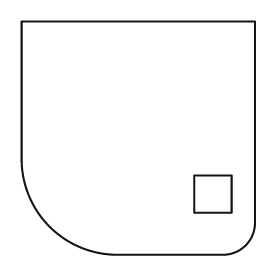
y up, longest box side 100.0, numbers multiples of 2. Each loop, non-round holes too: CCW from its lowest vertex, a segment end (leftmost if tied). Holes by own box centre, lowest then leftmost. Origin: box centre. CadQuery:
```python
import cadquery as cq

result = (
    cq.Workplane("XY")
    .moveTo(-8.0, -50.0)
    .lineTo(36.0, -50.0)
    .threePointArc((46.0, -46.0), (50.0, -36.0))
    .lineTo(50.0, 50.0)
    .lineTo(-50.0, 50.0)
    .lineTo(-50.0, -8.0)
    .threePointArc((-38.0, -38.0), (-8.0, -50.0))
    .close()
    .moveTo(24.0, -32.0)
    .lineTo(40.0, -32.0)
    .lineTo(40.0, -16.0)
    .lineTo(24.0, -16.0)
    .close()
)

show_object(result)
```